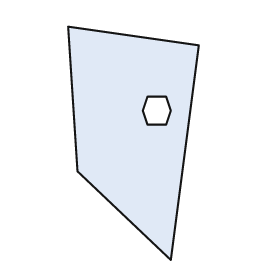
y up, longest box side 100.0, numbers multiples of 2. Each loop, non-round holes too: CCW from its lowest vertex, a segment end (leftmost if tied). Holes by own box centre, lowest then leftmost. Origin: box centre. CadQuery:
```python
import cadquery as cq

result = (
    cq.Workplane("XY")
    .moveTo(16.0, -50.0)
    .lineTo(28.0, 42.0)
    .lineTo(-28.0, 50.0)
    .lineTo(-24.0, -12.0)
    .close()
    .moveTo(6.0, 8.0)
    .lineTo(14.0, 8.0)
    .lineTo(16.0, 14.0)
    .lineTo(14.0, 20.0)
    .lineTo(6.0, 20.0)
    .lineTo(4.0, 14.0)
    .close()
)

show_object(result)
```